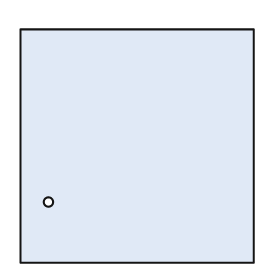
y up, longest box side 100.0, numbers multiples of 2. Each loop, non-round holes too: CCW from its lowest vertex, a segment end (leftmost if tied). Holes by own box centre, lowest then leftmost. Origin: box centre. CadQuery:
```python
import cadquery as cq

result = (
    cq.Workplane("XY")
    .moveTo(-50.0, -50.0)
    .lineTo(50.0, -50.0)
    .lineTo(50.0, 50.0)
    .lineTo(-50.0, 50.0)
    .close()
    .moveTo(-38.0, -24.0)
    .circle(2.0)
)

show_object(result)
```